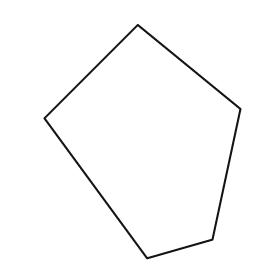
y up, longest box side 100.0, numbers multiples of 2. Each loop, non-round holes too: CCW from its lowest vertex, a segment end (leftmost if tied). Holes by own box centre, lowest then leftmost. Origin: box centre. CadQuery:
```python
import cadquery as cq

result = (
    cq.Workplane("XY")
    .moveTo(2.0, -50.0)
    .lineTo(30.0, -42.0)
    .lineTo(42.0, 14.0)
    .lineTo(-2.0, 50.0)
    .lineTo(-42.0, 10.0)
    .close()
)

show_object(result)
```